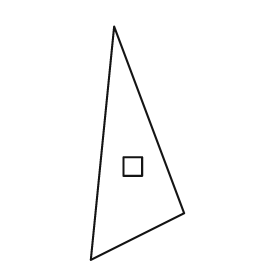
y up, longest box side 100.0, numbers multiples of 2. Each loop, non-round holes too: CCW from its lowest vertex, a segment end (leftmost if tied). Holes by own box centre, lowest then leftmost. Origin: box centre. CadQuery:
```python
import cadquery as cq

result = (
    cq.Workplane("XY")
    .moveTo(-20.0, -50.0)
    .lineTo(20.0, -30.0)
    .lineTo(-10.0, 50.0)
    .close()
    .moveTo(-6.0, -14.0)
    .lineTo(2.0, -14.0)
    .lineTo(2.0, -6.0)
    .lineTo(-6.0, -6.0)
    .close()
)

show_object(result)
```